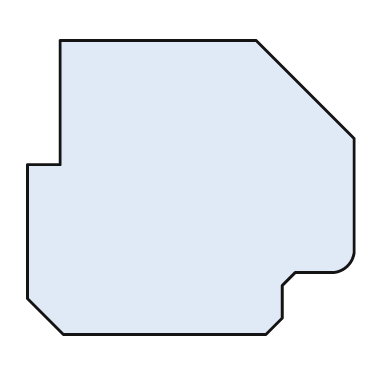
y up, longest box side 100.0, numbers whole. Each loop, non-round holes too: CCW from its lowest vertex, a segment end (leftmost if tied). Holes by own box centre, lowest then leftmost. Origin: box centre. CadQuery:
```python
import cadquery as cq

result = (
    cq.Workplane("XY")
    .moveTo(-39.0, -45.0)
    .lineTo(23.0, -45.0)
    .lineTo(28.0, -40.0)
    .lineTo(28.0, -30.0)
    .lineTo(32.0, -26.0)
    .lineTo(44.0, -26.0)
    .threePointArc((48.0, -24.0), (50.0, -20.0))
    .lineTo(50.0, 15.0)
    .lineTo(20.0, 45.0)
    .lineTo(-40.0, 45.0)
    .lineTo(-40.0, 7.0)
    .lineTo(-50.0, 7.0)
    .lineTo(-50.0, -34.0)
    .close()
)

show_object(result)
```